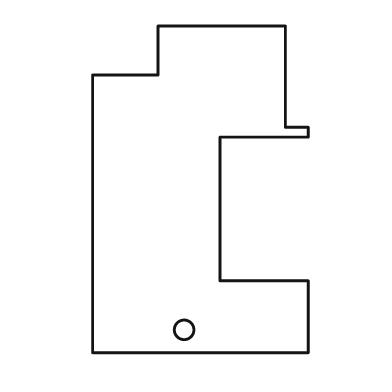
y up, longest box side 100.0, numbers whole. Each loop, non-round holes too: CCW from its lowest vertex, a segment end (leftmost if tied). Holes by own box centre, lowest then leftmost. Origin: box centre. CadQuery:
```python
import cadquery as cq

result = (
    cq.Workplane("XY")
    .moveTo(-33.0, -50.0)
    .lineTo(33.0, -50.0)
    .lineTo(33.0, -28.0)
    .lineTo(6.0, -28.0)
    .lineTo(6.0, 16.0)
    .lineTo(33.0, 16.0)
    .lineTo(33.0, 19.0)
    .lineTo(26.0, 19.0)
    .lineTo(26.0, 50.0)
    .lineTo(-13.0, 50.0)
    .lineTo(-13.0, 35.0)
    .lineTo(-33.0, 35.0)
    .close()
    .moveTo(-5.0, -43.0)
    .circle(3.0)
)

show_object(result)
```